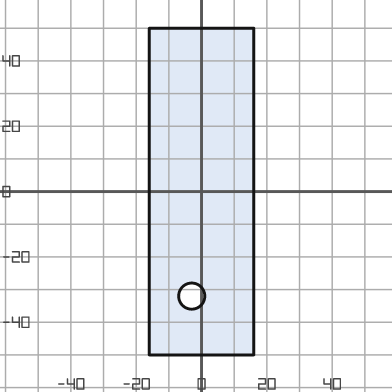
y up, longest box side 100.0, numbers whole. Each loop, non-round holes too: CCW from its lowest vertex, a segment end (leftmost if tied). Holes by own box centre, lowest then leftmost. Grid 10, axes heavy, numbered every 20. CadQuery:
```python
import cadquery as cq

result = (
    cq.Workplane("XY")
    .moveTo(-16.0, -50.0)
    .lineTo(16.0, -50.0)
    .lineTo(16.0, 50.0)
    .lineTo(-16.0, 50.0)
    .close()
    .moveTo(-3.0, -32.0)
    .circle(4.0)
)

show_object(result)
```